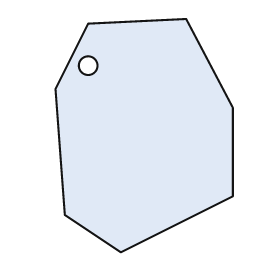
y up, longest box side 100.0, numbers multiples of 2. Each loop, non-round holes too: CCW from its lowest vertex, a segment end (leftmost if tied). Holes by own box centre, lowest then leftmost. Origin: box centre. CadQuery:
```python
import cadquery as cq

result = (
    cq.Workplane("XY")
    .moveTo(-10.0, -50.0)
    .lineTo(38.0, -26.0)
    .lineTo(38.0, 12.0)
    .lineTo(18.0, 50.0)
    .lineTo(-24.0, 48.0)
    .lineTo(-38.0, 20.0)
    .lineTo(-34.0, -34.0)
    .close()
    .moveTo(-24.0, 30.0)
    .circle(4.0)
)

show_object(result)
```